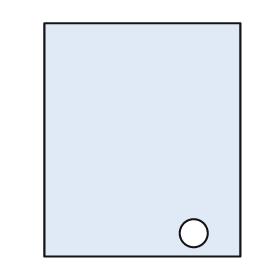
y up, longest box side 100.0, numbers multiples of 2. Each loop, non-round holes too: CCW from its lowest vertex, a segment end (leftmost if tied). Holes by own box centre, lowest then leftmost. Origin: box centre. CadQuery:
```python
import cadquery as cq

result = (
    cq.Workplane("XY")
    .moveTo(-42.0, -50.0)
    .lineTo(42.0, -50.0)
    .lineTo(42.0, 50.0)
    .lineTo(-42.0, 50.0)
    .close()
    .moveTo(22.0, -40.0)
    .circle(6.0)
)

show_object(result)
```